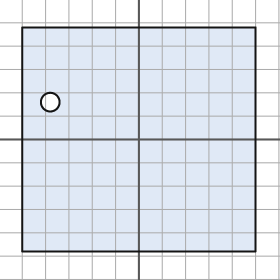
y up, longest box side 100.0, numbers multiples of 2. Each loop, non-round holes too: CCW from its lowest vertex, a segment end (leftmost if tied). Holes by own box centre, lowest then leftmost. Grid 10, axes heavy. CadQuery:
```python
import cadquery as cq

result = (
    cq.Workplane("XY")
    .moveTo(-50.0, -48.0)
    .lineTo(50.0, -48.0)
    .lineTo(50.0, 48.0)
    .lineTo(-50.0, 48.0)
    .close()
    .moveTo(-38.0, 16.0)
    .circle(4.0)
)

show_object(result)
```